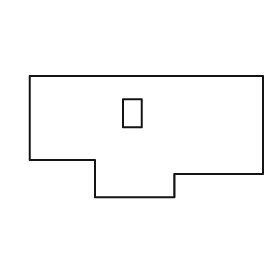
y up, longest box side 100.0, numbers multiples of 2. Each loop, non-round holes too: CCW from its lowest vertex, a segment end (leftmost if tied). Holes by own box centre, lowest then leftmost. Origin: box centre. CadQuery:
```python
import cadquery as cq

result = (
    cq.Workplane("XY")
    .moveTo(-22.0, -26.0)
    .lineTo(12.0, -26.0)
    .lineTo(12.0, -16.0)
    .lineTo(50.0, -16.0)
    .lineTo(50.0, 26.0)
    .lineTo(-50.0, 26.0)
    .lineTo(-50.0, -10.0)
    .lineTo(-22.0, -10.0)
    .close()
    .moveTo(-10.0, 4.0)
    .lineTo(-2.0, 4.0)
    .lineTo(-2.0, 16.0)
    .lineTo(-10.0, 16.0)
    .close()
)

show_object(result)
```